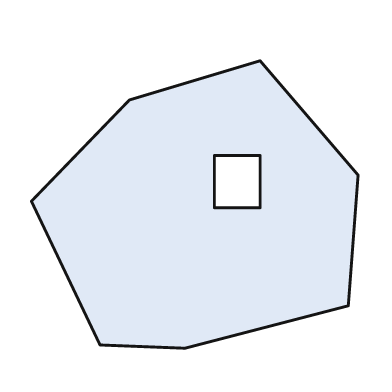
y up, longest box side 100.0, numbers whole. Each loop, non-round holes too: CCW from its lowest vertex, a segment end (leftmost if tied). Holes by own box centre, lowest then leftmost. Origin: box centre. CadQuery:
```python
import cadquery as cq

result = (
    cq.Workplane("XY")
    .moveTo(-3.0, -44.0)
    .lineTo(47.0, -31.0)
    .lineTo(50.0, 9.0)
    .lineTo(20.0, 44.0)
    .lineTo(-20.0, 32.0)
    .lineTo(-50.0, 1.0)
    .lineTo(-29.0, -43.0)
    .close()
    .moveTo(6.0, -1.0)
    .lineTo(20.0, -1.0)
    .lineTo(20.0, 15.0)
    .lineTo(6.0, 15.0)
    .close()
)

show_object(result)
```